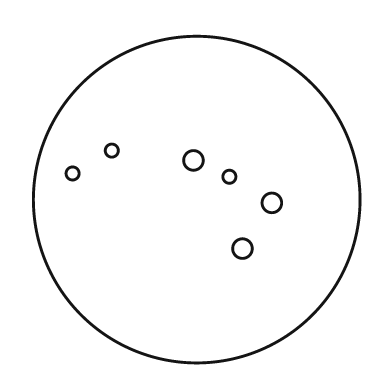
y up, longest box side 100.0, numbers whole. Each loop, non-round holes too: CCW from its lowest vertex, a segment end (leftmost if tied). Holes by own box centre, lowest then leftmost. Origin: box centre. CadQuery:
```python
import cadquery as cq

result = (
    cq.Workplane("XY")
    .moveTo(0.0, 0.0)
    .circle(50.0)
    .moveTo(14.0, -15.0)
    .circle(3.0)
    .moveTo(23.0, -1.0)
    .circle(3.0)
    .moveTo(10.0, 7.0)
    .circle(2.0)
    .moveTo(-38.0, 8.0)
    .circle(2.0)
    .moveTo(-1.0, 12.0)
    .circle(3.0)
    .moveTo(-26.0, 15.0)
    .circle(2.0)
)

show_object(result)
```